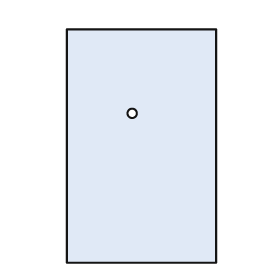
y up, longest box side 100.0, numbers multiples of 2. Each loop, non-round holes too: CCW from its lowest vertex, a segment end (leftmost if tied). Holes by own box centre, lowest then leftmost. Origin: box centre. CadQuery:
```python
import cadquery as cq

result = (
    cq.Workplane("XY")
    .moveTo(-32.0, -50.0)
    .lineTo(32.0, -50.0)
    .lineTo(32.0, 50.0)
    .lineTo(-32.0, 50.0)
    .close()
    .moveTo(-4.0, 14.0)
    .circle(2.0)
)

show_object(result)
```